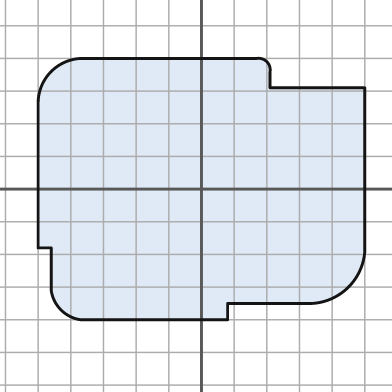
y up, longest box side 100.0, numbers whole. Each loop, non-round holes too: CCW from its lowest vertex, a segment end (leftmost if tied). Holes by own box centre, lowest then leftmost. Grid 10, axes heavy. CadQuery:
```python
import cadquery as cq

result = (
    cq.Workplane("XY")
    .moveTo(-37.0, -40.0)
    .lineTo(8.0, -40.0)
    .lineTo(8.0, -35.0)
    .lineTo(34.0, -35.0)
    .threePointArc((45.0, -30.0), (50.0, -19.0))
    .lineTo(50.0, 31.0)
    .lineTo(21.0, 31.0)
    .lineTo(21.0, 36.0)
    .threePointArc((20.0, 39.0), (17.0, 40.0))
    .lineTo(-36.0, 40.0)
    .threePointArc((-46.0, 36.0), (-50.0, 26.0))
    .lineTo(-50.0, -18.0)
    .lineTo(-46.0, -18.0)
    .lineTo(-46.0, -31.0)
    .threePointArc((-43.0, -37.0), (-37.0, -40.0))
    .close()
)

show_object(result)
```